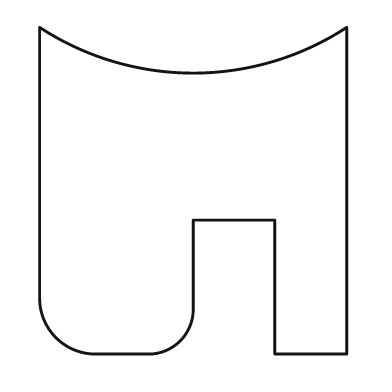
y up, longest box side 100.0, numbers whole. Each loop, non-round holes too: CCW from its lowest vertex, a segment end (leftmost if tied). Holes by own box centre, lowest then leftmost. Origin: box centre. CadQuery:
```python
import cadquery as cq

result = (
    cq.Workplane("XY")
    .moveTo(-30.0, -50.0)
    .lineTo(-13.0, -50.0)
    .threePointArc((-4.0, -46.0), (0.0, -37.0))
    .lineTo(0.0, -9.0)
    .lineTo(25.0, -9.0)
    .lineTo(25.0, -50.0)
    .lineTo(47.0, -50.0)
    .lineTo(47.0, 50.0)
    .threePointArc((0.0, 36.0), (-47.0, 50.0))
    .lineTo(-47.0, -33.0)
    .threePointArc((-42.0, -45.0), (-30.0, -50.0))
    .close()
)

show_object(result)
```